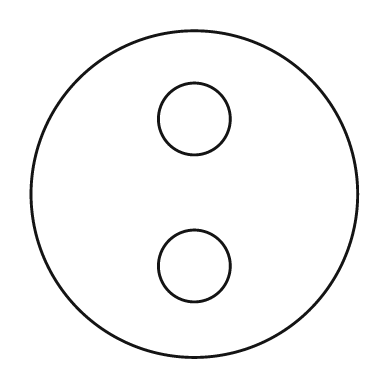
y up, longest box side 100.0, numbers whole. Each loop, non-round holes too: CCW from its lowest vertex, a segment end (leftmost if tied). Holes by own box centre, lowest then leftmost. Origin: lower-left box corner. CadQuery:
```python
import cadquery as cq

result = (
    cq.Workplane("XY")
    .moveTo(50.0, 50.0)
    .circle(50.0)
    .moveTo(50.0, 28.0)
    .circle(11.0)
    .moveTo(50.0, 73.0)
    .circle(11.0)
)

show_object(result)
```